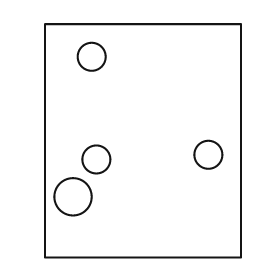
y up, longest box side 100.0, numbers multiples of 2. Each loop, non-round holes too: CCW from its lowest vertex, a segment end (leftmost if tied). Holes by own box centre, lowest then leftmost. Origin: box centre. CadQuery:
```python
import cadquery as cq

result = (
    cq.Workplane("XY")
    .moveTo(-42.0, -50.0)
    .lineTo(42.0, -50.0)
    .lineTo(42.0, 50.0)
    .lineTo(-42.0, 50.0)
    .close()
    .moveTo(-30.0, -24.0)
    .circle(8.0)
    .moveTo(-20.0, -8.0)
    .circle(6.0)
    .moveTo(28.0, -6.0)
    .circle(6.0)
    .moveTo(-22.0, 36.0)
    .circle(6.0)
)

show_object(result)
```